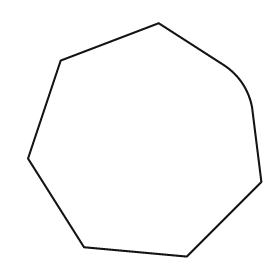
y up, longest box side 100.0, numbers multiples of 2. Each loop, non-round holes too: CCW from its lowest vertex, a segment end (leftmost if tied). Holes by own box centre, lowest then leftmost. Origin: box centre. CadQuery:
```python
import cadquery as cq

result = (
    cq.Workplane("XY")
    .moveTo(18.0, -50.0)
    .lineTo(50.0, -18.0)
    .lineTo(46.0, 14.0)
    .threePointArc((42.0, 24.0), (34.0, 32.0))
    .lineTo(6.0, 50.0)
    .lineTo(-36.0, 34.0)
    .lineTo(-50.0, -8.0)
    .lineTo(-26.0, -46.0)
    .close()
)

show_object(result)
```